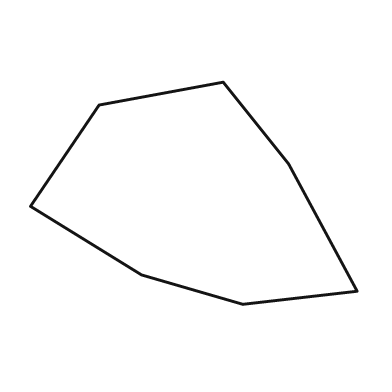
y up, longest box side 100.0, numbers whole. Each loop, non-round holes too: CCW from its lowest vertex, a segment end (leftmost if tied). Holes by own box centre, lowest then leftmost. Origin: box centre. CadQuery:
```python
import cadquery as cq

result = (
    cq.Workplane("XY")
    .moveTo(15.0, -34.0)
    .lineTo(50.0, -30.0)
    .lineTo(29.0, 9.0)
    .lineTo(9.0, 34.0)
    .lineTo(-29.0, 27.0)
    .lineTo(-50.0, -4.0)
    .lineTo(-16.0, -25.0)
    .close()
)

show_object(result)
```